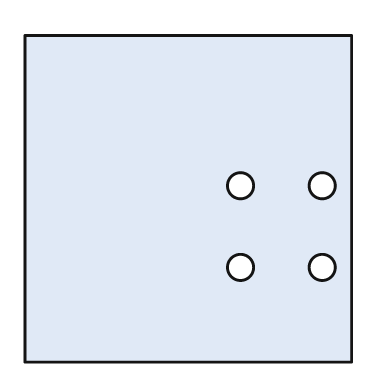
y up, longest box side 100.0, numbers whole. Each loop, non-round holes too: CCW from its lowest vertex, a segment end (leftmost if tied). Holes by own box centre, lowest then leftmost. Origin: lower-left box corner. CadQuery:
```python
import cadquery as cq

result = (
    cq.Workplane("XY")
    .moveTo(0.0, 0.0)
    .lineTo(100.0, 0.0)
    .lineTo(100.0, 100.0)
    .lineTo(0.0, 100.0)
    .close()
    .moveTo(66.0, 29.0)
    .circle(4.0)
    .moveTo(91.0, 29.0)
    .circle(4.0)
    .moveTo(66.0, 54.0)
    .circle(4.0)
    .moveTo(91.0, 54.0)
    .circle(4.0)
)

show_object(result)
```